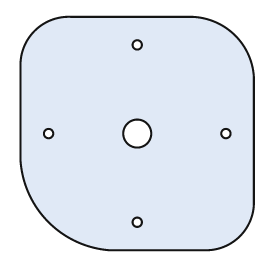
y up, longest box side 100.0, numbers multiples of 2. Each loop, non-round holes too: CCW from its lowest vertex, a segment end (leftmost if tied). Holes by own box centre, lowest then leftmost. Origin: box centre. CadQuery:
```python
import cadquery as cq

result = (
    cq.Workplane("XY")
    .moveTo(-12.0, -50.0)
    .lineTo(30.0, -50.0)
    .threePointArc((44.0, -44.0), (50.0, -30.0))
    .lineTo(50.0, 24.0)
    .threePointArc((42.0, 42.0), (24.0, 50.0))
    .lineTo(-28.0, 50.0)
    .threePointArc((-44.0, 44.0), (-50.0, 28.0))
    .lineTo(-50.0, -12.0)
    .threePointArc((-38.0, -38.0), (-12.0, -50.0))
    .close()
    .moveTo(0.0, -38.0)
    .circle(2.0)
    .moveTo(-38.0, 0.0)
    .circle(2.0)
    .moveTo(0.0, 0.0)
    .circle(6.0)
    .moveTo(38.0, 0.0)
    .circle(2.0)
    .moveTo(0.0, 38.0)
    .circle(2.0)
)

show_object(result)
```